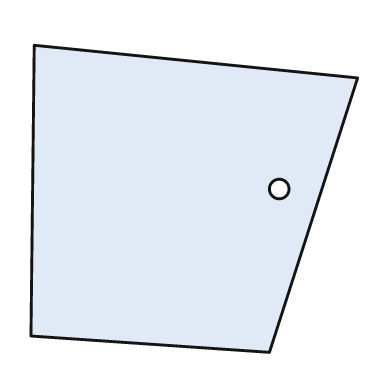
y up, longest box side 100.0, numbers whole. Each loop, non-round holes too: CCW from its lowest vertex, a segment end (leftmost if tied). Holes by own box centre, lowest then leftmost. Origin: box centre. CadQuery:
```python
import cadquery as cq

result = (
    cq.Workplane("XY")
    .moveTo(23.0, -47.0)
    .lineTo(50.0, 37.0)
    .lineTo(-49.0, 47.0)
    .lineTo(-50.0, -42.0)
    .close()
    .moveTo(26.0, 3.0)
    .circle(3.0)
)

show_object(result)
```